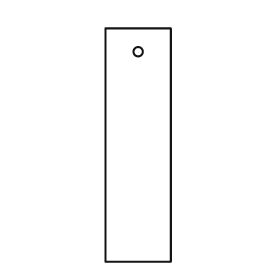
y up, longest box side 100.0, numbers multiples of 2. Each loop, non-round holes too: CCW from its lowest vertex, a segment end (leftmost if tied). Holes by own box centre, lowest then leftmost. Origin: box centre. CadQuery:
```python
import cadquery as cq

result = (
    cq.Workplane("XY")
    .moveTo(-14.0, -50.0)
    .lineTo(14.0, -50.0)
    .lineTo(14.0, 50.0)
    .lineTo(-14.0, 50.0)
    .close()
    .moveTo(0.0, 40.0)
    .circle(2.0)
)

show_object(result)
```